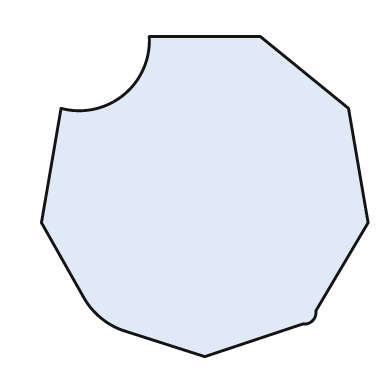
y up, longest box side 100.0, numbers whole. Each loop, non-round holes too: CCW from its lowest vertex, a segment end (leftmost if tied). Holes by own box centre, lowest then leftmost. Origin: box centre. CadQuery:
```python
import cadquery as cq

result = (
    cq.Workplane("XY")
    .moveTo(0.0, -49.0)
    .lineTo(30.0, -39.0)
    .threePointArc((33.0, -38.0), (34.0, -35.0))
    .lineTo(50.0, -8.0)
    .lineTo(44.0, 27.0)
    .lineTo(17.0, 49.0)
    .lineTo(-17.0, 49.0)
    .threePointArc((-25.0, 31.0), (-44.0, 27.0))
    .lineTo(-50.0, -8.0)
    .lineTo(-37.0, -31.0)
    .threePointArc((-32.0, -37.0), (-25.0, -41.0))
    .close()
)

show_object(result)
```